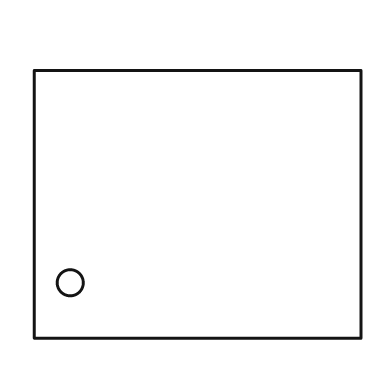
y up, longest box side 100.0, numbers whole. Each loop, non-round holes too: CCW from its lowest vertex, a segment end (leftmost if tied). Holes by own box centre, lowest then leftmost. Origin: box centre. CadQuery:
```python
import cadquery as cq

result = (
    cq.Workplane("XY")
    .moveTo(-50.0, -41.0)
    .lineTo(50.0, -41.0)
    .lineTo(50.0, 41.0)
    .lineTo(-50.0, 41.0)
    .close()
    .moveTo(-39.0, -24.0)
    .circle(4.0)
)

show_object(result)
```